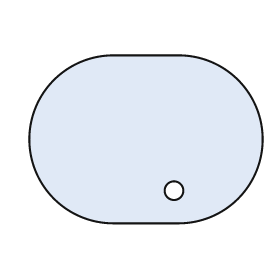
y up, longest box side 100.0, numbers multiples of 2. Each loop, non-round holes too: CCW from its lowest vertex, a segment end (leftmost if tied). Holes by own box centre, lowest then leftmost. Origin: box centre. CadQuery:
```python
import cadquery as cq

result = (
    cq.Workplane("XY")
    .moveTo(-14.0, -36.0)
    .lineTo(14.0, -36.0)
    .threePointArc((50.0, 0.0), (14.0, 36.0))
    .lineTo(-14.0, 36.0)
    .threePointArc((-50.0, 0.0), (-14.0, -36.0))
    .close()
    .moveTo(12.0, -22.0)
    .circle(4.0)
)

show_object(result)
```